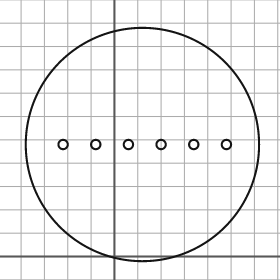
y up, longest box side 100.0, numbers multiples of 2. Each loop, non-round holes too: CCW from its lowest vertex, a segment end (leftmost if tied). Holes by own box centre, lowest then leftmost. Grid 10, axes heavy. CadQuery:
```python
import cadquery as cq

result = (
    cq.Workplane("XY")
    .moveTo(12.0, 48.0)
    .circle(50.0)
    .moveTo(-22.0, 48.0)
    .circle(2.0)
    .moveTo(-8.0, 48.0)
    .circle(2.0)
    .moveTo(6.0, 48.0)
    .circle(2.0)
    .moveTo(20.0, 48.0)
    .circle(2.0)
    .moveTo(34.0, 48.0)
    .circle(2.0)
    .moveTo(48.0, 48.0)
    .circle(2.0)
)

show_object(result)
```